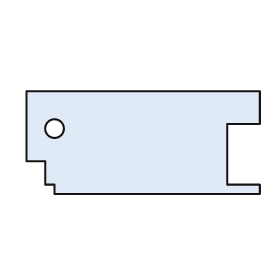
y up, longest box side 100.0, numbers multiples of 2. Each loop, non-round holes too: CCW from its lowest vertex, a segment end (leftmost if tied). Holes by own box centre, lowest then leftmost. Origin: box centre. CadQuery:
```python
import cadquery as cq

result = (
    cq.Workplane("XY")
    .moveTo(-38.0, -22.0)
    .lineTo(50.0, -22.0)
    .lineTo(50.0, -18.0)
    .lineTo(36.0, -18.0)
    .lineTo(36.0, 8.0)
    .lineTo(50.0, 8.0)
    .lineTo(50.0, 22.0)
    .lineTo(-50.0, 22.0)
    .lineTo(-50.0, -8.0)
    .lineTo(-42.0, -8.0)
    .lineTo(-42.0, -18.0)
    .lineTo(-38.0, -18.0)
    .close()
    .moveTo(-38.0, 6.0)
    .circle(4.0)
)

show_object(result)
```